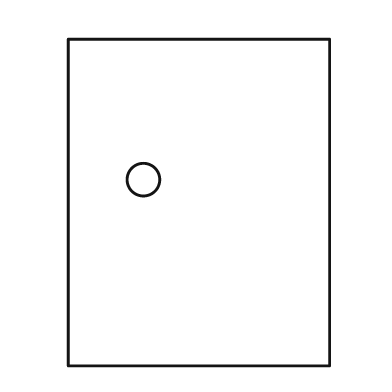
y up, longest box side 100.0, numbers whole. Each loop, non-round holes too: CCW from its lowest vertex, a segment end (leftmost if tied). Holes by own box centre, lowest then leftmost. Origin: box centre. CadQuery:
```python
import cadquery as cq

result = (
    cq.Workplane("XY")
    .moveTo(-40.0, -50.0)
    .lineTo(40.0, -50.0)
    .lineTo(40.0, 50.0)
    .lineTo(-40.0, 50.0)
    .close()
    .moveTo(-17.0, 7.0)
    .circle(5.0)
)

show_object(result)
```